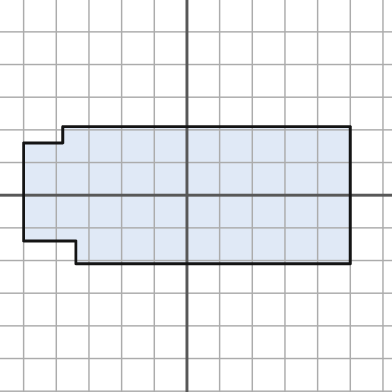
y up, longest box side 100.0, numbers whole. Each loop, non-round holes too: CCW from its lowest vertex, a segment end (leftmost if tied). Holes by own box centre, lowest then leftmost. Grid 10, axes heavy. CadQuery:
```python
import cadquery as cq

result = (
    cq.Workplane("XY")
    .moveTo(-34.0, -21.0)
    .lineTo(50.0, -21.0)
    .lineTo(50.0, 21.0)
    .lineTo(-38.0, 21.0)
    .lineTo(-38.0, 16.0)
    .lineTo(-50.0, 16.0)
    .lineTo(-50.0, -14.0)
    .lineTo(-34.0, -14.0)
    .close()
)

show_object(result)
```